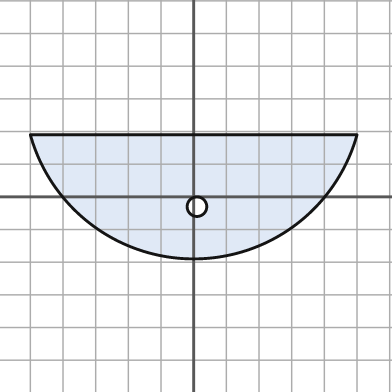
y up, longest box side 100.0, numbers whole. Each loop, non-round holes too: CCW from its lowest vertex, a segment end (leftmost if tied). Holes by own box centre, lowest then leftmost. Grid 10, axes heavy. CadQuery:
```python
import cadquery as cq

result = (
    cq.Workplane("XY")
    .moveTo(-50.0, 19.0)
    .threePointArc((0.0, -19.0), (50.0, 19.0))
    .close()
    .moveTo(1.0, -3.0)
    .circle(3.0)
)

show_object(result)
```